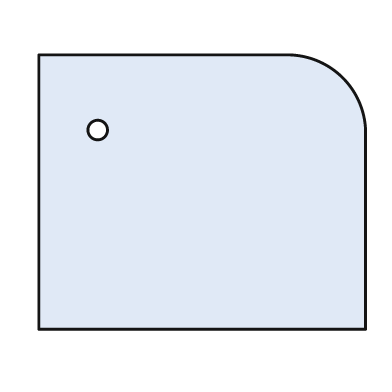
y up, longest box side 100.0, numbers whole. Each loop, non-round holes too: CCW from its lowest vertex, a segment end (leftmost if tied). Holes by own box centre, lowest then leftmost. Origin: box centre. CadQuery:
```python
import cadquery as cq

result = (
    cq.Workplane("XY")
    .moveTo(-50.0, -42.0)
    .lineTo(50.0, -42.0)
    .lineTo(50.0, 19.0)
    .threePointArc((43.0, 35.0), (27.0, 42.0))
    .lineTo(-50.0, 42.0)
    .close()
    .moveTo(-32.0, 19.0)
    .circle(3.0)
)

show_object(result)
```